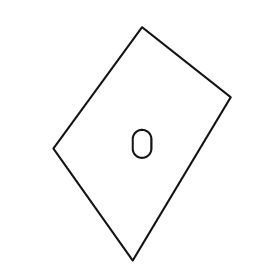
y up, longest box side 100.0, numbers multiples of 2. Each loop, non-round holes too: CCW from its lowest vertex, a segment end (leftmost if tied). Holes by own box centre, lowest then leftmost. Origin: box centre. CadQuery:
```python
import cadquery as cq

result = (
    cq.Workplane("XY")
    .moveTo(-4.0, -50.0)
    .lineTo(38.0, 20.0)
    .lineTo(0.0, 50.0)
    .lineTo(-38.0, -2.0)
    .close()
    .moveTo(-4.0, -2.0)
    .threePointArc((0.0, -6.0), (4.0, -2.0))
    .lineTo(4.0, 2.0)
    .threePointArc((0.0, 6.0), (-4.0, 2.0))
    .close()
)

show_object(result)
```